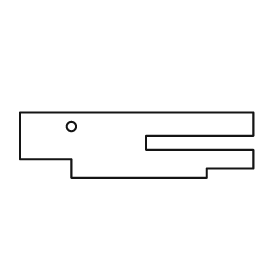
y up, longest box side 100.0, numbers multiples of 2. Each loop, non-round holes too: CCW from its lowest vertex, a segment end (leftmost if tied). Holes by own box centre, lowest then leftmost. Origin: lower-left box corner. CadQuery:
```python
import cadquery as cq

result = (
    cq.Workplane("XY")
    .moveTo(22.0, 0.0)
    .lineTo(80.0, 0.0)
    .lineTo(80.0, 4.0)
    .lineTo(100.0, 4.0)
    .lineTo(100.0, 12.0)
    .lineTo(54.0, 12.0)
    .lineTo(54.0, 18.0)
    .lineTo(100.0, 18.0)
    .lineTo(100.0, 28.0)
    .lineTo(0.0, 28.0)
    .lineTo(0.0, 8.0)
    .lineTo(22.0, 8.0)
    .close()
    .moveTo(22.0, 22.0)
    .circle(2.0)
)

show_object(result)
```